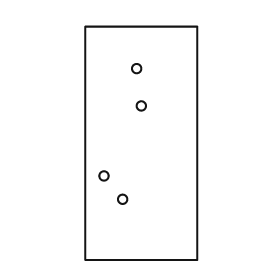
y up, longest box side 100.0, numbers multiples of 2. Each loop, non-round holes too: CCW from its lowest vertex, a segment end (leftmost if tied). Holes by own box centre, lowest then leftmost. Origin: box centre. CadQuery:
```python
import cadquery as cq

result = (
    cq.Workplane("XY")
    .moveTo(-24.0, -50.0)
    .lineTo(24.0, -50.0)
    .lineTo(24.0, 50.0)
    .lineTo(-24.0, 50.0)
    .close()
    .moveTo(-8.0, -24.0)
    .circle(2.0)
    .moveTo(-16.0, -14.0)
    .circle(2.0)
    .moveTo(0.0, 16.0)
    .circle(2.0)
    .moveTo(-2.0, 32.0)
    .circle(2.0)
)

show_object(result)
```